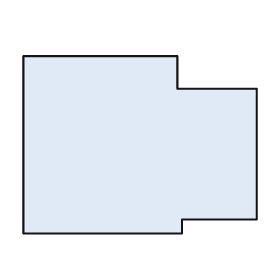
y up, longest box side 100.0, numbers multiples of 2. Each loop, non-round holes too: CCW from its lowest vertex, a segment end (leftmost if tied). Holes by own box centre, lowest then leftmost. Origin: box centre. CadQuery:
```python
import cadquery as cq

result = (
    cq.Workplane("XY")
    .moveTo(-50.0, -38.0)
    .lineTo(18.0, -38.0)
    .lineTo(18.0, -32.0)
    .lineTo(50.0, -32.0)
    .lineTo(50.0, 24.0)
    .lineTo(16.0, 24.0)
    .lineTo(16.0, 38.0)
    .lineTo(-50.0, 38.0)
    .close()
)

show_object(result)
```